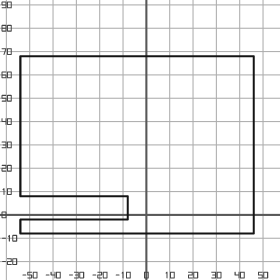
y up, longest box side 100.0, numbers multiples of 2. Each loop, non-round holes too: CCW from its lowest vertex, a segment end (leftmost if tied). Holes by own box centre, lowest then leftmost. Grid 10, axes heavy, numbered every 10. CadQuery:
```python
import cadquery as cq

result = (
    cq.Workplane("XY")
    .moveTo(-54.0, -8.0)
    .lineTo(46.0, -8.0)
    .lineTo(46.0, 68.0)
    .lineTo(-54.0, 68.0)
    .lineTo(-54.0, 8.0)
    .lineTo(-8.0, 8.0)
    .lineTo(-8.0, -2.0)
    .lineTo(-54.0, -2.0)
    .close()
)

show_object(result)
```